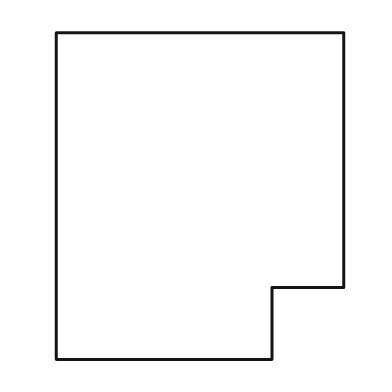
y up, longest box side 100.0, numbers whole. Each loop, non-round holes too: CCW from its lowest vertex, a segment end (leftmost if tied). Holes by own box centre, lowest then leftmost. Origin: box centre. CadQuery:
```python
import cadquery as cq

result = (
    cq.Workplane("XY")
    .moveTo(-44.0, -50.0)
    .lineTo(22.0, -50.0)
    .lineTo(22.0, -28.0)
    .lineTo(44.0, -28.0)
    .lineTo(44.0, 50.0)
    .lineTo(-44.0, 50.0)
    .close()
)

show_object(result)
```